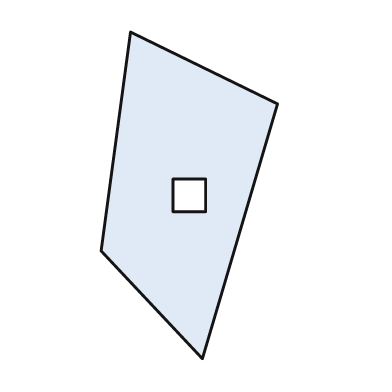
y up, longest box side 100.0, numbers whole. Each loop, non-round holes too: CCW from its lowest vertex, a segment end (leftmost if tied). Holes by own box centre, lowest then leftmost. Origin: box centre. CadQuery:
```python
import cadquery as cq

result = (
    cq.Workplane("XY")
    .moveTo(4.0, -50.0)
    .lineTo(27.0, 28.0)
    .lineTo(-18.0, 50.0)
    .lineTo(-27.0, -17.0)
    .close()
    .moveTo(-5.0, -5.0)
    .lineTo(5.0, -5.0)
    .lineTo(5.0, 5.0)
    .lineTo(-5.0, 5.0)
    .close()
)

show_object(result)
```